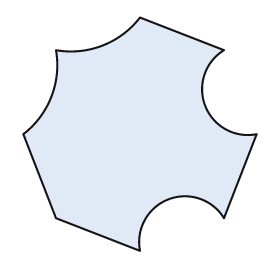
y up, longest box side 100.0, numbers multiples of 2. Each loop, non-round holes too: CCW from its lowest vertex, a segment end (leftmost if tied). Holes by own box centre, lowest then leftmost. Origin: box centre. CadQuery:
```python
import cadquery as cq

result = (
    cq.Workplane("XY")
    .moveTo(0.0, -50.0)
    .threePointArc((12.0, -28.0), (36.0, -36.0))
    .lineTo(50.0, 0.0)
    .threePointArc((28.0, 12.0), (36.0, 36.0))
    .lineTo(0.0, 50.0)
    .threePointArc((-16.0, 38.0), (-36.0, 36.0))
    .threePointArc((-38.0, 16.0), (-50.0, 0.0))
    .lineTo(-36.0, -36.0)
    .close()
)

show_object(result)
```